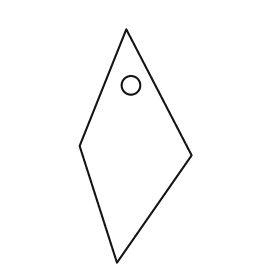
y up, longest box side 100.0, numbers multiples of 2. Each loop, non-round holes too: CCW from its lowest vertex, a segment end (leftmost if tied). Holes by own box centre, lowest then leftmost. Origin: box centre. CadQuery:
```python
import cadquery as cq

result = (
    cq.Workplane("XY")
    .moveTo(-8.0, -50.0)
    .lineTo(24.0, -4.0)
    .lineTo(-4.0, 50.0)
    .lineTo(-24.0, 0.0)
    .close()
    .moveTo(-2.0, 26.0)
    .circle(4.0)
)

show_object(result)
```